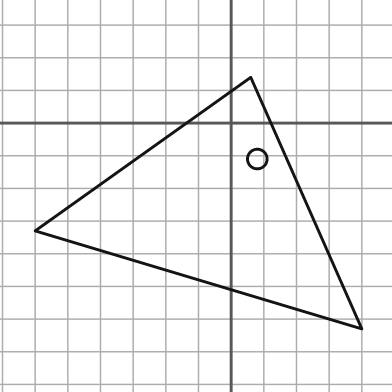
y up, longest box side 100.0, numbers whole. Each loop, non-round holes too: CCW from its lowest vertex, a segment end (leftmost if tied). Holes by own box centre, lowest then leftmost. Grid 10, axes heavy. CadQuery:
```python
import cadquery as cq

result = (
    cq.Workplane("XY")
    .moveTo(40.0, -63.0)
    .lineTo(6.0, 14.0)
    .lineTo(-60.0, -33.0)
    .close()
    .moveTo(8.0, -11.0)
    .circle(3.0)
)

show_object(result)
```